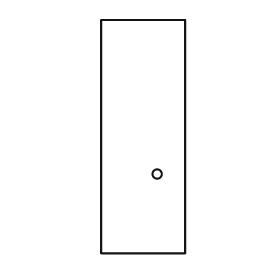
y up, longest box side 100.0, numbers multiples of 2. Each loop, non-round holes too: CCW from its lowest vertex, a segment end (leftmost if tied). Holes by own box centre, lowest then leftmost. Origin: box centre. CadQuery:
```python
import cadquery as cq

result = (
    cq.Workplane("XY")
    .moveTo(-18.0, -50.0)
    .lineTo(18.0, -50.0)
    .lineTo(18.0, 50.0)
    .lineTo(-18.0, 50.0)
    .close()
    .moveTo(6.0, -16.0)
    .circle(2.0)
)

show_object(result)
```